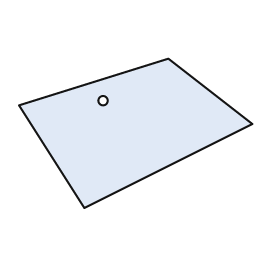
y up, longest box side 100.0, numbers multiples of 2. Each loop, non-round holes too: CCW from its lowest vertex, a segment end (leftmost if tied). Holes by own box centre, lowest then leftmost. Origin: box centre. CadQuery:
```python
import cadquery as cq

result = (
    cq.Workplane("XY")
    .moveTo(-22.0, -32.0)
    .lineTo(50.0, 4.0)
    .lineTo(14.0, 32.0)
    .lineTo(-50.0, 12.0)
    .close()
    .moveTo(-14.0, 14.0)
    .circle(2.0)
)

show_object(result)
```